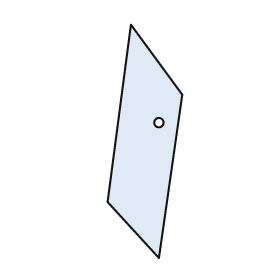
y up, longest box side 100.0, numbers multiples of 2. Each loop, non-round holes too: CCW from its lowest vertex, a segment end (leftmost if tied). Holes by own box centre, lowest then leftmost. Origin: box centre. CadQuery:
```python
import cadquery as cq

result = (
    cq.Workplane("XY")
    .moveTo(6.0, -50.0)
    .lineTo(16.0, 20.0)
    .lineTo(-6.0, 50.0)
    .lineTo(-16.0, -26.0)
    .close()
    .moveTo(6.0, 8.0)
    .circle(2.0)
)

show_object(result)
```